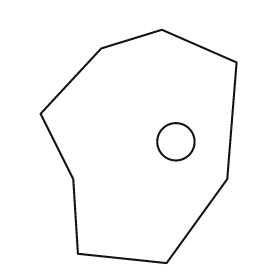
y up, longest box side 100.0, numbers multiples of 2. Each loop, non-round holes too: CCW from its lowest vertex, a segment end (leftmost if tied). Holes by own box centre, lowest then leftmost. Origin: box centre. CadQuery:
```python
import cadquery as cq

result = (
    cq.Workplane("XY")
    .moveTo(12.0, -50.0)
    .lineTo(38.0, -14.0)
    .lineTo(42.0, 36.0)
    .lineTo(10.0, 50.0)
    .lineTo(-16.0, 42.0)
    .lineTo(-42.0, 14.0)
    .lineTo(-28.0, -14.0)
    .lineTo(-26.0, -46.0)
    .close()
    .moveTo(16.0, 2.0)
    .circle(8.0)
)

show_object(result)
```